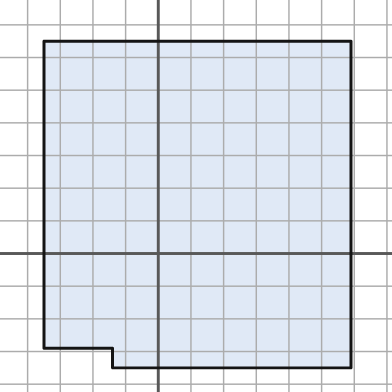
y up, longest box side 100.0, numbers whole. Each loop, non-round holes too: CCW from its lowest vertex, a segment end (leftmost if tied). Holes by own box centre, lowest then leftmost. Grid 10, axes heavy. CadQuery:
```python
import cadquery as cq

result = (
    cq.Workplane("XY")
    .moveTo(-14.0, -35.0)
    .lineTo(59.0, -35.0)
    .lineTo(59.0, 65.0)
    .lineTo(-35.0, 65.0)
    .lineTo(-35.0, -29.0)
    .lineTo(-14.0, -29.0)
    .close()
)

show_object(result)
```